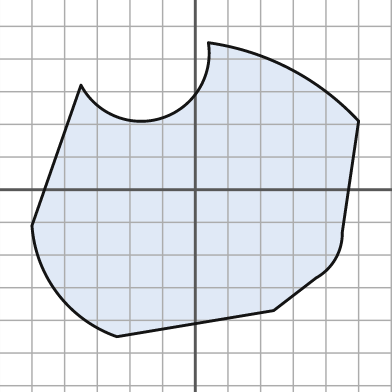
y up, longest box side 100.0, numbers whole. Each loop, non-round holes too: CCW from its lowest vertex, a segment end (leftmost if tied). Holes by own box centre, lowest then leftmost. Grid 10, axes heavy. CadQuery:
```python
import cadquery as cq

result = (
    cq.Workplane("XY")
    .moveTo(-24.0, -45.0)
    .lineTo(24.0, -37.0)
    .lineTo(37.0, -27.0)
    .threePointArc((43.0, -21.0), (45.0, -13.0))
    .lineTo(50.0, 21.0)
    .threePointArc((29.0, 37.0), (4.0, 45.0))
    .threePointArc((-10.0, 22.0), (-35.0, 32.0))
    .lineTo(-50.0, -11.0)
    .threePointArc((-42.0, -32.0), (-24.0, -45.0))
    .close()
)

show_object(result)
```